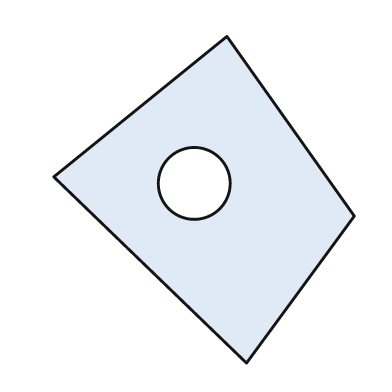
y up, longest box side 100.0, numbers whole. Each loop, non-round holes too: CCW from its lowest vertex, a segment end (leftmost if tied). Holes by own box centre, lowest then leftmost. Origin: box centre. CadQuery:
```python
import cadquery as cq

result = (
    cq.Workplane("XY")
    .moveTo(13.0, -50.0)
    .lineTo(46.0, -5.0)
    .lineTo(7.0, 50.0)
    .lineTo(-46.0, 7.0)
    .close()
    .moveTo(-3.0, 5.0)
    .circle(11.0)
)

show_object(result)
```